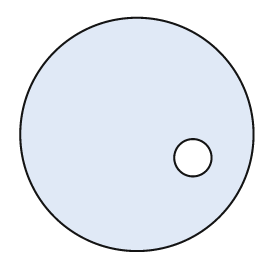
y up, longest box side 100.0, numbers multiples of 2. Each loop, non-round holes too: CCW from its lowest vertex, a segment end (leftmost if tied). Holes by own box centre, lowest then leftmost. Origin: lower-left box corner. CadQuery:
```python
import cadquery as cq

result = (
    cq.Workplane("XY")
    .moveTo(50.0, 50.0)
    .circle(50.0)
    .moveTo(74.0, 40.0)
    .circle(8.0)
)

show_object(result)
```